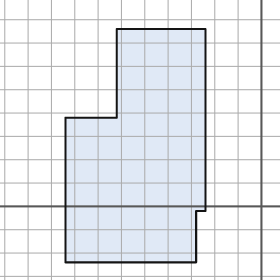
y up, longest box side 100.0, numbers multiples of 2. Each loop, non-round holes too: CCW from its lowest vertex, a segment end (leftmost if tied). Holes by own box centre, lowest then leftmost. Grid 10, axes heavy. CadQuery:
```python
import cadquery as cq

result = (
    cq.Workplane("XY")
    .moveTo(-84.0, -24.0)
    .lineTo(-28.0, -24.0)
    .lineTo(-28.0, -2.0)
    .lineTo(-24.0, -2.0)
    .lineTo(-24.0, 76.0)
    .lineTo(-62.0, 76.0)
    .lineTo(-62.0, 38.0)
    .lineTo(-84.0, 38.0)
    .close()
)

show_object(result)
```